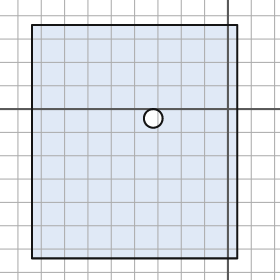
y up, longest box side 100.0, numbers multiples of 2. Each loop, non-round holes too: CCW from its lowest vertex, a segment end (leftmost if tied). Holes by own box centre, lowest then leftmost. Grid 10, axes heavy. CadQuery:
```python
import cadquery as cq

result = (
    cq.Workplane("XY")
    .moveTo(-84.0, -64.0)
    .lineTo(4.0, -64.0)
    .lineTo(4.0, 36.0)
    .lineTo(-84.0, 36.0)
    .close()
    .moveTo(-32.0, -4.0)
    .circle(4.0)
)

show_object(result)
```